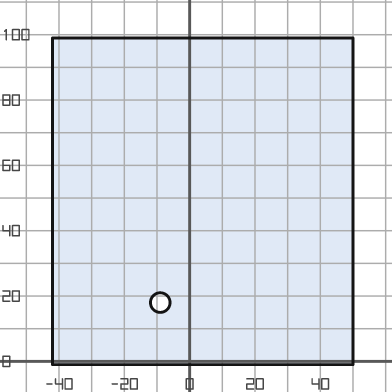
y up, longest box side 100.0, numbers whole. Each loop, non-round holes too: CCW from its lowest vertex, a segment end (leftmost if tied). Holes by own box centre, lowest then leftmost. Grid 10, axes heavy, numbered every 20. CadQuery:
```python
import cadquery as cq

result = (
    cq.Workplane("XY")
    .moveTo(-42.0, -1.0)
    .lineTo(50.0, -1.0)
    .lineTo(50.0, 99.0)
    .lineTo(-42.0, 99.0)
    .close()
    .moveTo(-9.0, 18.0)
    .circle(3.0)
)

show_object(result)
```